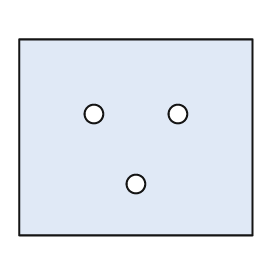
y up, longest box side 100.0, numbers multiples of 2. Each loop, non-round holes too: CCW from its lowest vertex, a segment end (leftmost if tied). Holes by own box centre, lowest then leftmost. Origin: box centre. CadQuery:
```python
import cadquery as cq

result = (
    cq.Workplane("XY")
    .moveTo(-50.0, -42.0)
    .lineTo(50.0, -42.0)
    .lineTo(50.0, 42.0)
    .lineTo(-50.0, 42.0)
    .close()
    .moveTo(0.0, -20.0)
    .circle(4.0)
    .moveTo(-18.0, 10.0)
    .circle(4.0)
    .moveTo(18.0, 10.0)
    .circle(4.0)
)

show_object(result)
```